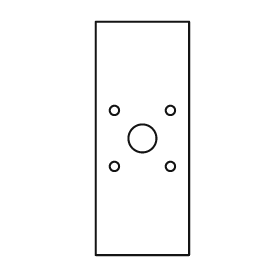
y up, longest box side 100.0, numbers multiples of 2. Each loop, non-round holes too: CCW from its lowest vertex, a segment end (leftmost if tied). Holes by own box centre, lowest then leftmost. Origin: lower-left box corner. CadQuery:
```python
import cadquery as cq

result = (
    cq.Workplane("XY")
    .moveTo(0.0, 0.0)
    .lineTo(40.0, 0.0)
    .lineTo(40.0, 100.0)
    .lineTo(0.0, 100.0)
    .close()
    .moveTo(8.0, 38.0)
    .circle(2.0)
    .moveTo(32.0, 38.0)
    .circle(2.0)
    .moveTo(20.0, 50.0)
    .circle(6.0)
    .moveTo(8.0, 62.0)
    .circle(2.0)
    .moveTo(32.0, 62.0)
    .circle(2.0)
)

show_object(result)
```